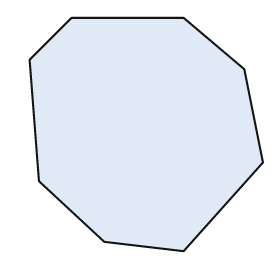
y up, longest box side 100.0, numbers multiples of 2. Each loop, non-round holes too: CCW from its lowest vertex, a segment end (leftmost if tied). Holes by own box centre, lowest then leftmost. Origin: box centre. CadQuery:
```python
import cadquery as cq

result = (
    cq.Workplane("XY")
    .moveTo(16.0, -50.0)
    .lineTo(50.0, -12.0)
    .lineTo(42.0, 28.0)
    .lineTo(16.0, 50.0)
    .lineTo(-32.0, 50.0)
    .lineTo(-50.0, 32.0)
    .lineTo(-46.0, -20.0)
    .lineTo(-18.0, -46.0)
    .close()
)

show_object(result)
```